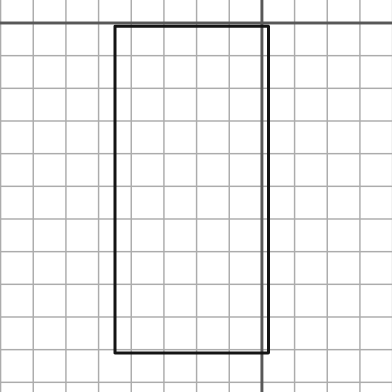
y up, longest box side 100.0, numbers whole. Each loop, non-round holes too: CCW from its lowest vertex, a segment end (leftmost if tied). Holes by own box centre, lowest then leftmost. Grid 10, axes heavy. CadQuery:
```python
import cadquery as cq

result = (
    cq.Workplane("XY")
    .moveTo(-45.0, -101.0)
    .lineTo(2.0, -101.0)
    .lineTo(2.0, -1.0)
    .lineTo(-45.0, -1.0)
    .close()
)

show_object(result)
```